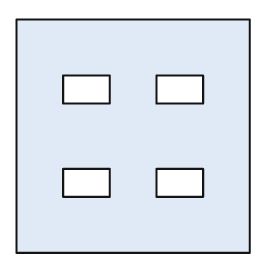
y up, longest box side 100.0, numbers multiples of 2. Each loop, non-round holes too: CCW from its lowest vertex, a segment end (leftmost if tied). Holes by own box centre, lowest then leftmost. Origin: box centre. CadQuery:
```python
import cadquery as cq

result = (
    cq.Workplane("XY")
    .moveTo(-50.0, -50.0)
    .lineTo(50.0, -50.0)
    .lineTo(50.0, 50.0)
    .lineTo(-50.0, 50.0)
    .close()
    .moveTo(-30.0, -26.0)
    .lineTo(-10.0, -26.0)
    .lineTo(-10.0, -14.0)
    .lineTo(-30.0, -14.0)
    .close()
    .moveTo(10.0, -26.0)
    .lineTo(30.0, -26.0)
    .lineTo(30.0, -14.0)
    .lineTo(10.0, -14.0)
    .close()
    .moveTo(-30.0, 14.0)
    .lineTo(-10.0, 14.0)
    .lineTo(-10.0, 26.0)
    .lineTo(-30.0, 26.0)
    .close()
    .moveTo(10.0, 14.0)
    .lineTo(30.0, 14.0)
    .lineTo(30.0, 26.0)
    .lineTo(10.0, 26.0)
    .close()
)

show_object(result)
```